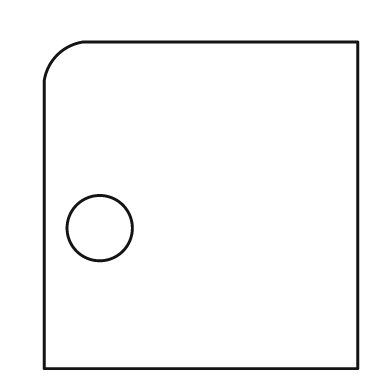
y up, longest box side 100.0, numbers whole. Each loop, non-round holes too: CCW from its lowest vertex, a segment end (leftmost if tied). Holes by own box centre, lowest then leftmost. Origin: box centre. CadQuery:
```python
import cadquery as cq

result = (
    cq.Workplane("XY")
    .moveTo(-48.0, -50.0)
    .lineTo(48.0, -50.0)
    .lineTo(48.0, 50.0)
    .lineTo(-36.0, 50.0)
    .threePointArc((-44.0, 46.0), (-48.0, 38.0))
    .close()
    .moveTo(-31.0, -7.0)
    .circle(10.0)
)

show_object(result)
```